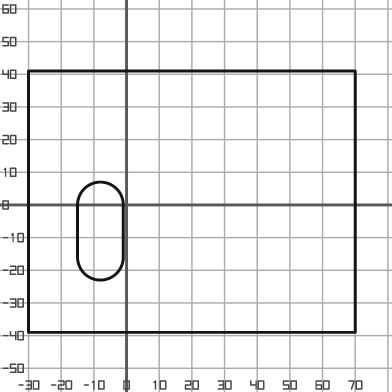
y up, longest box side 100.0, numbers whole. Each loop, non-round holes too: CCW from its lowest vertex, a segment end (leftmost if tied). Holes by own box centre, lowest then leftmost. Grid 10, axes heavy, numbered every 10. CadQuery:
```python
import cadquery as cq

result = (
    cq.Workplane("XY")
    .moveTo(-30.0, -39.0)
    .lineTo(70.0, -39.0)
    .lineTo(70.0, 41.0)
    .lineTo(-30.0, 41.0)
    .close()
    .moveTo(-15.0, -16.0)
    .threePointArc((-8.0, -23.0), (-1.0, -16.0))
    .lineTo(-1.0, 0.0)
    .threePointArc((-8.0, 7.0), (-15.0, 0.0))
    .close()
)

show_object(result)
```